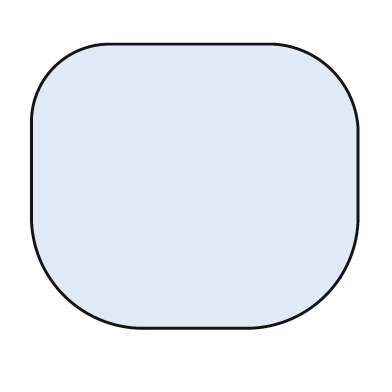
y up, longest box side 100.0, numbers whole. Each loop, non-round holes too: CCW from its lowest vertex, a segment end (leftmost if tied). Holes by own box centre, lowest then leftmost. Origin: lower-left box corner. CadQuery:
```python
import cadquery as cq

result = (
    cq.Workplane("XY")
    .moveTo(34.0, 0.0)
    .lineTo(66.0, 0.0)
    .threePointArc((90.0, 10.0), (100.0, 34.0))
    .lineTo(100.0, 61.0)
    .threePointArc((92.0, 79.0), (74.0, 87.0))
    .lineTo(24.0, 87.0)
    .threePointArc((7.0, 80.0), (0.0, 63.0))
    .lineTo(0.0, 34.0)
    .threePointArc((10.0, 10.0), (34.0, 0.0))
    .close()
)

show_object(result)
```